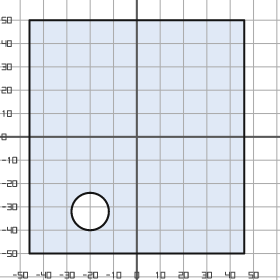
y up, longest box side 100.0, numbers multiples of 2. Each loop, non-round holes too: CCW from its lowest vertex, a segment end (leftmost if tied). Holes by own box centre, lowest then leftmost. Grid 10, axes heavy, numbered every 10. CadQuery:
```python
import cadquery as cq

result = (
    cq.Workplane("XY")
    .moveTo(-46.0, -50.0)
    .lineTo(46.0, -50.0)
    .lineTo(46.0, 50.0)
    .lineTo(-46.0, 50.0)
    .close()
    .moveTo(-20.0, -32.0)
    .circle(8.0)
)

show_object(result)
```